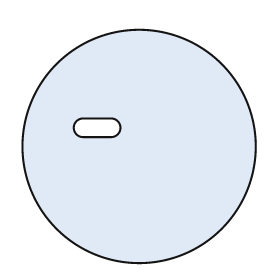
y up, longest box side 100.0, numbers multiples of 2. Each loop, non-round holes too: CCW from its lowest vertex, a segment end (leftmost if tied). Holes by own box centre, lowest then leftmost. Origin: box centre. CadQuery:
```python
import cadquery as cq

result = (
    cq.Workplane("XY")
    .moveTo(0.0, 0.0)
    .circle(50.0)
    .moveTo(-24.0, 4.0)
    .lineTo(-12.0, 4.0)
    .threePointArc((-8.0, 8.0), (-12.0, 12.0))
    .lineTo(-24.0, 12.0)
    .threePointArc((-28.0, 8.0), (-24.0, 4.0))
    .close()
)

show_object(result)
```